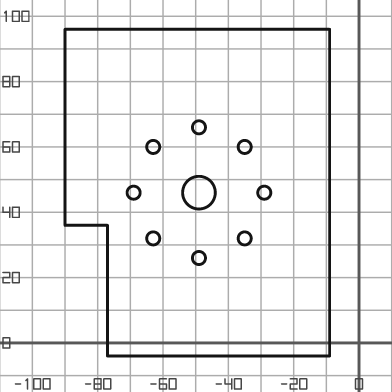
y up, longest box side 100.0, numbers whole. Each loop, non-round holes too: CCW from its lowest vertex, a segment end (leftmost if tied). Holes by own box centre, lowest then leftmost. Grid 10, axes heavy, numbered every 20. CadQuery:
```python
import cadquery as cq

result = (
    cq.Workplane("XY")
    .moveTo(-77.0, -4.0)
    .lineTo(-9.0, -4.0)
    .lineTo(-9.0, 96.0)
    .lineTo(-90.0, 96.0)
    .lineTo(-90.0, 36.0)
    .lineTo(-77.0, 36.0)
    .close()
    .moveTo(-49.0, 26.0)
    .circle(2.0)
    .moveTo(-63.0, 32.0)
    .circle(2.0)
    .moveTo(-35.0, 32.0)
    .circle(2.0)
    .moveTo(-69.0, 46.0)
    .circle(2.0)
    .moveTo(-49.0, 46.0)
    .circle(5.0)
    .moveTo(-29.0, 46.0)
    .circle(2.0)
    .moveTo(-63.0, 60.0)
    .circle(2.0)
    .moveTo(-35.0, 60.0)
    .circle(2.0)
    .moveTo(-49.0, 66.0)
    .circle(2.0)
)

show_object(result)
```